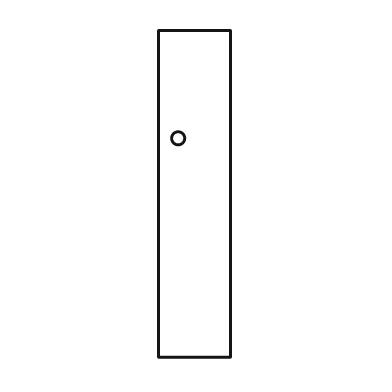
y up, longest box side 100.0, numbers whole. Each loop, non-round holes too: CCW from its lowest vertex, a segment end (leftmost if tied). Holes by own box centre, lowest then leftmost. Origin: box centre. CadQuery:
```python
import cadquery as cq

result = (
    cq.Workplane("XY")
    .moveTo(-11.0, -50.0)
    .lineTo(11.0, -50.0)
    .lineTo(11.0, 50.0)
    .lineTo(-11.0, 50.0)
    .close()
    .moveTo(-5.0, 17.0)
    .circle(2.0)
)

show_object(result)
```